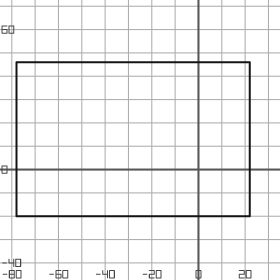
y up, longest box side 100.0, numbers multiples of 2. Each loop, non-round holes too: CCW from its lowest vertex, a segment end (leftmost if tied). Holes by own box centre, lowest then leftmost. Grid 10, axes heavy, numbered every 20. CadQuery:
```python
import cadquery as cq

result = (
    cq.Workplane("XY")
    .moveTo(-78.0, -20.0)
    .lineTo(22.0, -20.0)
    .lineTo(22.0, 46.0)
    .lineTo(-78.0, 46.0)
    .close()
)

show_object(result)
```